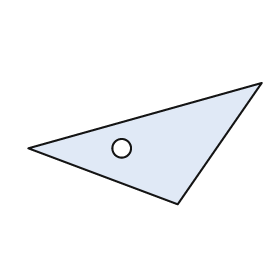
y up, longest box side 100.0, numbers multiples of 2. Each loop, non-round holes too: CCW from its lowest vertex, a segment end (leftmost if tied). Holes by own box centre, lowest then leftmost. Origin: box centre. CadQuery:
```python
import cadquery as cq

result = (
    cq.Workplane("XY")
    .moveTo(14.0, -26.0)
    .lineTo(50.0, 26.0)
    .lineTo(-50.0, -2.0)
    .close()
    .moveTo(-10.0, -2.0)
    .circle(4.0)
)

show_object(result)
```